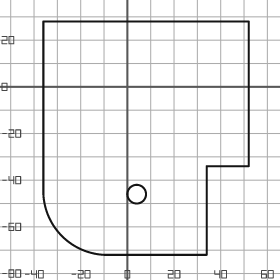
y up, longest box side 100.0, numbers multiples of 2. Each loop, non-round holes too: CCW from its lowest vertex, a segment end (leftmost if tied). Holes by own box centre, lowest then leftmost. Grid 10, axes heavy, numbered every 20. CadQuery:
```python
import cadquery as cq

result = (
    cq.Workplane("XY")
    .moveTo(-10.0, -72.0)
    .lineTo(34.0, -72.0)
    .lineTo(34.0, -34.0)
    .lineTo(52.0, -34.0)
    .lineTo(52.0, 28.0)
    .lineTo(-36.0, 28.0)
    .lineTo(-36.0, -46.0)
    .threePointArc((-28.0, -64.0), (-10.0, -72.0))
    .close()
    .moveTo(4.0, -46.0)
    .circle(4.0)
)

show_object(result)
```